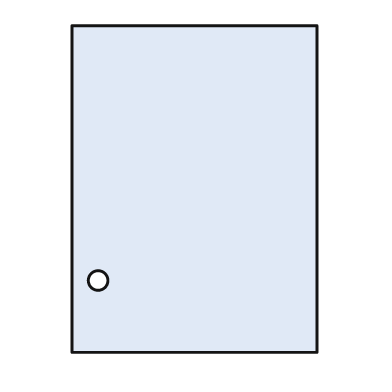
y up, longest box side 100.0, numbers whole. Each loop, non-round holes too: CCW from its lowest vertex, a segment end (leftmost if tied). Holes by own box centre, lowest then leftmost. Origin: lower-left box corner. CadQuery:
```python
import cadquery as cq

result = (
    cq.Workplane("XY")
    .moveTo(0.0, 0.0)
    .lineTo(75.0, 0.0)
    .lineTo(75.0, 100.0)
    .lineTo(0.0, 100.0)
    .close()
    .moveTo(8.0, 22.0)
    .circle(3.0)
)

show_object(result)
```